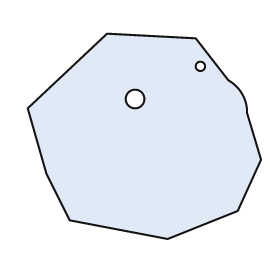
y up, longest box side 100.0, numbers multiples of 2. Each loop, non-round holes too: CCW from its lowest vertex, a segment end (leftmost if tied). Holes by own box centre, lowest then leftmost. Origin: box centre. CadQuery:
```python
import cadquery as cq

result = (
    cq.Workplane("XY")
    .moveTo(10.0, -44.0)
    .lineTo(40.0, -32.0)
    .lineTo(50.0, -10.0)
    .lineTo(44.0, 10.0)
    .threePointArc((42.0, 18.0), (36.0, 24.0))
    .lineTo(22.0, 42.0)
    .lineTo(-16.0, 44.0)
    .lineTo(-50.0, 12.0)
    .lineTo(-42.0, -16.0)
    .lineTo(-32.0, -36.0)
    .close()
    .moveTo(-4.0, 16.0)
    .circle(4.0)
    .moveTo(24.0, 30.0)
    .circle(2.0)
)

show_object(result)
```